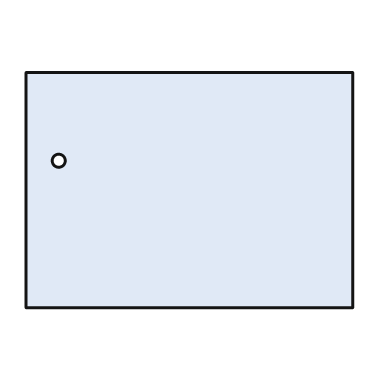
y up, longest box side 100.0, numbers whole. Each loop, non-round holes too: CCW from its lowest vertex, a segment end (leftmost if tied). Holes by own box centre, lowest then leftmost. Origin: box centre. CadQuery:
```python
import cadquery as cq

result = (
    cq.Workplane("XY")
    .moveTo(-50.0, -36.0)
    .lineTo(50.0, -36.0)
    .lineTo(50.0, 36.0)
    .lineTo(-50.0, 36.0)
    .close()
    .moveTo(-40.0, 9.0)
    .circle(2.0)
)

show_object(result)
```